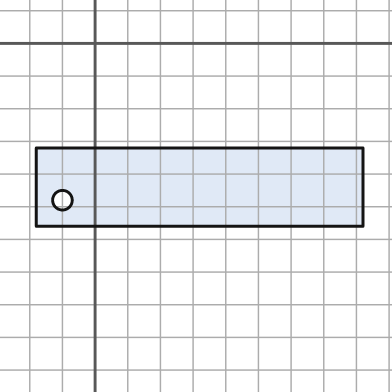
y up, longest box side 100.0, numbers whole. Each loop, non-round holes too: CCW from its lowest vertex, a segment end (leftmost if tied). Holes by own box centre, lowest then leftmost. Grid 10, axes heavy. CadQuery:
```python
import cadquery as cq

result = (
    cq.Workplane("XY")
    .moveTo(-18.0, -56.0)
    .lineTo(82.0, -56.0)
    .lineTo(82.0, -32.0)
    .lineTo(-18.0, -32.0)
    .close()
    .moveTo(-10.0, -48.0)
    .circle(3.0)
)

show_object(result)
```